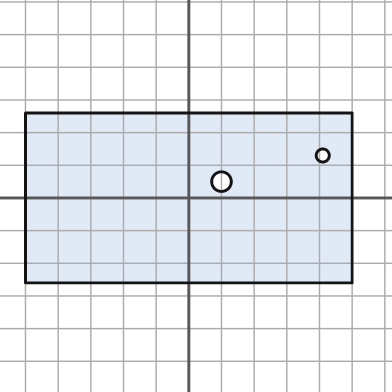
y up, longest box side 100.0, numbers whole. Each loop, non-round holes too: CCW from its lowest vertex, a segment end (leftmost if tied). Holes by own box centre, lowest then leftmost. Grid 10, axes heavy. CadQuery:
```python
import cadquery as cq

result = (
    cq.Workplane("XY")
    .moveTo(-50.0, -26.0)
    .lineTo(50.0, -26.0)
    .lineTo(50.0, 26.0)
    .lineTo(-50.0, 26.0)
    .close()
    .moveTo(10.0, 5.0)
    .circle(3.0)
    .moveTo(41.0, 13.0)
    .circle(2.0)
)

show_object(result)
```